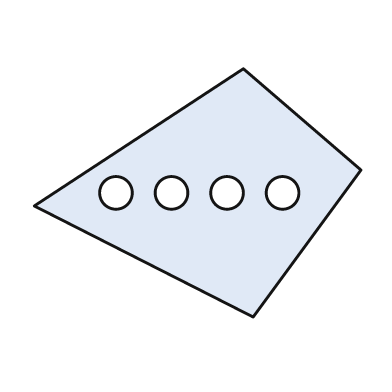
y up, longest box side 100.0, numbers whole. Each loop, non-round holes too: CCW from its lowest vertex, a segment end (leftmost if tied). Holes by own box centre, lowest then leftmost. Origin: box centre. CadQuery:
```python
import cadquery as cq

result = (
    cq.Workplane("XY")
    .moveTo(17.0, -38.0)
    .lineTo(50.0, 7.0)
    .lineTo(14.0, 38.0)
    .lineTo(-50.0, -4.0)
    .close()
    .moveTo(-25.0, 0.0)
    .circle(5.0)
    .moveTo(-8.0, 0.0)
    .circle(5.0)
    .moveTo(9.0, 0.0)
    .circle(5.0)
    .moveTo(26.0, 0.0)
    .circle(5.0)
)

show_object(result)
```